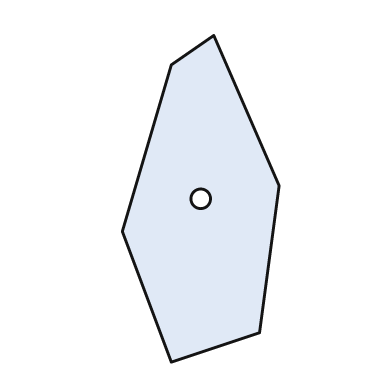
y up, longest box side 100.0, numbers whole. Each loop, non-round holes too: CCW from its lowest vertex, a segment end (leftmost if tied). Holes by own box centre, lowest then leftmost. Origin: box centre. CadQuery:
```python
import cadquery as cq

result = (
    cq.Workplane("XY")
    .moveTo(-9.0, -50.0)
    .lineTo(18.0, -41.0)
    .lineTo(24.0, 4.0)
    .lineTo(4.0, 50.0)
    .lineTo(-9.0, 41.0)
    .lineTo(-24.0, -10.0)
    .close()
    .moveTo(0.0, 0.0)
    .circle(3.0)
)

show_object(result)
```